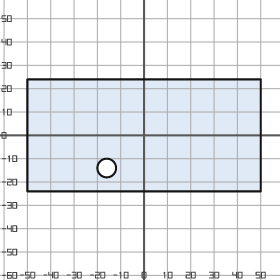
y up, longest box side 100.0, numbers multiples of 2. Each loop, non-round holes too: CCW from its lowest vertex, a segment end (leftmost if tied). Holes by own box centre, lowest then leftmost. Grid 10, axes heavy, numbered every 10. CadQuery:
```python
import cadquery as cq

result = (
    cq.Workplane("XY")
    .moveTo(-50.0, -24.0)
    .lineTo(50.0, -24.0)
    .lineTo(50.0, 24.0)
    .lineTo(-50.0, 24.0)
    .close()
    .moveTo(-16.0, -14.0)
    .circle(4.0)
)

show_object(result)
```